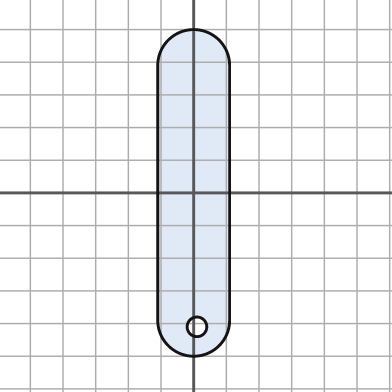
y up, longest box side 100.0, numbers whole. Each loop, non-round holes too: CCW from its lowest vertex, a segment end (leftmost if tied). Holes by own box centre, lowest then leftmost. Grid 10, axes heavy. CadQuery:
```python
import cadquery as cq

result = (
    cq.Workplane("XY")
    .moveTo(-11.0, -39.0)
    .threePointArc((0.0, -50.0), (11.0, -39.0))
    .lineTo(11.0, 39.0)
    .threePointArc((0.0, 50.0), (-11.0, 39.0))
    .close()
    .moveTo(1.0, -41.0)
    .circle(3.0)
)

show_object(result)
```